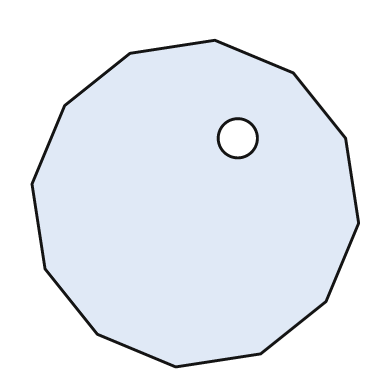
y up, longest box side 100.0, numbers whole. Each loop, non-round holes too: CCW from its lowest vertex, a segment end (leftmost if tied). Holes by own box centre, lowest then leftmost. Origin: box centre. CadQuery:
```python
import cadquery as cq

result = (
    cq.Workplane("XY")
    .moveTo(-6.0, -50.0)
    .lineTo(20.0, -46.0)
    .lineTo(40.0, -30.0)
    .lineTo(50.0, -6.0)
    .lineTo(46.0, 20.0)
    .lineTo(30.0, 40.0)
    .lineTo(6.0, 50.0)
    .lineTo(-20.0, 46.0)
    .lineTo(-40.0, 30.0)
    .lineTo(-50.0, 6.0)
    .lineTo(-46.0, -20.0)
    .lineTo(-30.0, -40.0)
    .close()
    .moveTo(13.0, 20.0)
    .circle(6.0)
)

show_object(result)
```